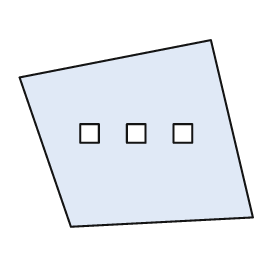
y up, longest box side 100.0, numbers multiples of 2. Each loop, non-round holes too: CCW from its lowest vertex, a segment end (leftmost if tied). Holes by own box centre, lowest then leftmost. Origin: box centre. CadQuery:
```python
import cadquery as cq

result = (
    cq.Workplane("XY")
    .moveTo(-28.0, -40.0)
    .lineTo(50.0, -36.0)
    .lineTo(32.0, 40.0)
    .lineTo(-50.0, 24.0)
    .close()
    .moveTo(-24.0, -4.0)
    .lineTo(-16.0, -4.0)
    .lineTo(-16.0, 4.0)
    .lineTo(-24.0, 4.0)
    .close()
    .moveTo(-4.0, -4.0)
    .lineTo(4.0, -4.0)
    .lineTo(4.0, 4.0)
    .lineTo(-4.0, 4.0)
    .close()
    .moveTo(16.0, -4.0)
    .lineTo(24.0, -4.0)
    .lineTo(24.0, 4.0)
    .lineTo(16.0, 4.0)
    .close()
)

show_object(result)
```